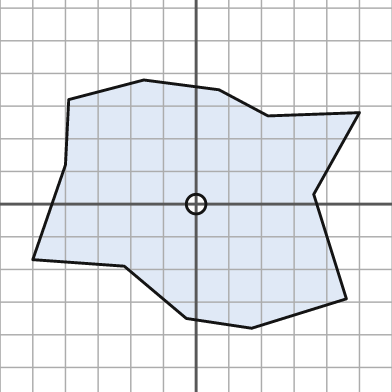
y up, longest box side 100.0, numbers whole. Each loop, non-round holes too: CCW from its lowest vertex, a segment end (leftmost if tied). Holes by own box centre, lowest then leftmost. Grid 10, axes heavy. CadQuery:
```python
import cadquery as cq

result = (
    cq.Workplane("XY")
    .moveTo(17.0, -38.0)
    .lineTo(46.0, -29.0)
    .lineTo(36.0, 3.0)
    .lineTo(50.0, 28.0)
    .lineTo(22.0, 27.0)
    .lineTo(7.0, 35.0)
    .lineTo(-16.0, 38.0)
    .lineTo(-39.0, 32.0)
    .lineTo(-40.0, 12.0)
    .lineTo(-50.0, -17.0)
    .lineTo(-22.0, -19.0)
    .lineTo(-3.0, -35.0)
    .close()
    .moveTo(0.0, 0.0)
    .circle(3.0)
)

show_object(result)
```